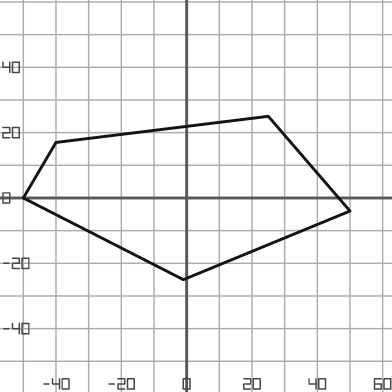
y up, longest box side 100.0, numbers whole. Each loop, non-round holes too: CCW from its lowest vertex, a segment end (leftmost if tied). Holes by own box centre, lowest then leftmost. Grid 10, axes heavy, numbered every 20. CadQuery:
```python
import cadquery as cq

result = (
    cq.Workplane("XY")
    .moveTo(-1.0, -25.0)
    .lineTo(50.0, -4.0)
    .lineTo(25.0, 25.0)
    .lineTo(-40.0, 17.0)
    .lineTo(-50.0, 0.0)
    .close()
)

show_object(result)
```